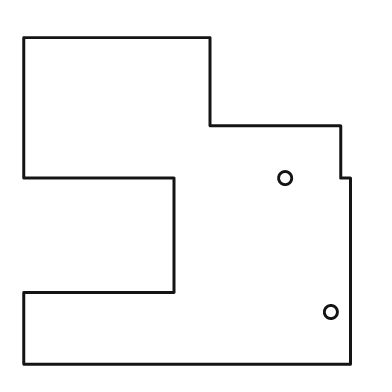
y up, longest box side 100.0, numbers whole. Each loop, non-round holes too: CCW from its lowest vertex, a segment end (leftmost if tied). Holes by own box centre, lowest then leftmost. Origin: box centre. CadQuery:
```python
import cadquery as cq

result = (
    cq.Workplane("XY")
    .moveTo(-50.0, -50.0)
    .lineTo(50.0, -50.0)
    .lineTo(50.0, 7.0)
    .lineTo(47.0, 7.0)
    .lineTo(47.0, 23.0)
    .lineTo(7.0, 23.0)
    .lineTo(7.0, 50.0)
    .lineTo(-50.0, 50.0)
    .lineTo(-50.0, 7.0)
    .lineTo(-4.0, 7.0)
    .lineTo(-4.0, -28.0)
    .lineTo(-50.0, -28.0)
    .close()
    .moveTo(44.0, -34.0)
    .circle(2.0)
    .moveTo(30.0, 7.0)
    .circle(2.0)
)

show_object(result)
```